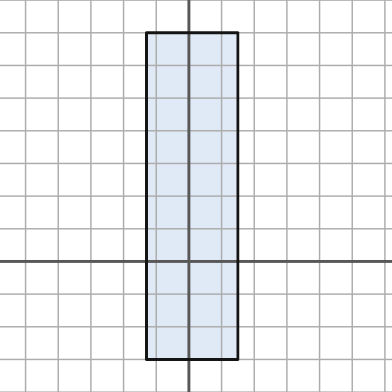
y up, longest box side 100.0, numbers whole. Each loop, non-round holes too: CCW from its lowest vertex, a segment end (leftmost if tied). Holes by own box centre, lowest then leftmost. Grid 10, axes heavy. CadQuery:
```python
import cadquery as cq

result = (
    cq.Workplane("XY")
    .moveTo(-13.0, -30.0)
    .lineTo(15.0, -30.0)
    .lineTo(15.0, 70.0)
    .lineTo(-13.0, 70.0)
    .close()
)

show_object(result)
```